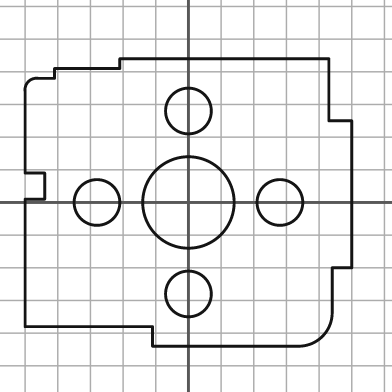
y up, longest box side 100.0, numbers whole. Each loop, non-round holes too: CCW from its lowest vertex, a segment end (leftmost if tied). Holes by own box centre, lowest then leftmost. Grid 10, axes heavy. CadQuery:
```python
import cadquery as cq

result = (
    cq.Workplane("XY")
    .moveTo(-11.0, -44.0)
    .lineTo(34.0, -44.0)
    .threePointArc((41.0, -41.0), (44.0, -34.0))
    .lineTo(44.0, -20.0)
    .lineTo(50.0, -20.0)
    .lineTo(50.0, 25.0)
    .lineTo(43.0, 25.0)
    .lineTo(43.0, 44.0)
    .lineTo(-21.0, 44.0)
    .lineTo(-21.0, 41.0)
    .lineTo(-41.0, 41.0)
    .lineTo(-41.0, 38.0)
    .lineTo(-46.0, 38.0)
    .threePointArc((-49.0, 37.0), (-50.0, 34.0))
    .lineTo(-50.0, 9.0)
    .lineTo(-44.0, 9.0)
    .lineTo(-44.0, 1.0)
    .lineTo(-50.0, 1.0)
    .lineTo(-50.0, -38.0)
    .lineTo(-11.0, -38.0)
    .close()
    .moveTo(0.0, -28.0)
    .circle(7.0)
    .moveTo(-28.0, 0.0)
    .circle(7.0)
    .moveTo(0.0, 0.0)
    .circle(14.0)
    .moveTo(28.0, 0.0)
    .circle(7.0)
    .moveTo(0.0, 28.0)
    .circle(7.0)
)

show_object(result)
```